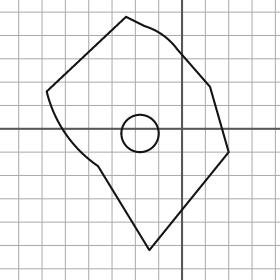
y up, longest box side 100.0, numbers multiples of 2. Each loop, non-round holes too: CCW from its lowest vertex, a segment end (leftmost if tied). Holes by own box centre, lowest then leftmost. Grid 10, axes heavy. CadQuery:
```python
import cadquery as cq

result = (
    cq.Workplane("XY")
    .moveTo(-14.0, -52.0)
    .lineTo(20.0, -10.0)
    .lineTo(12.0, 18.0)
    .lineTo(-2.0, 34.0)
    .threePointArc((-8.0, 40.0), (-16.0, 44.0))
    .lineTo(-24.0, 48.0)
    .lineTo(-58.0, 16.0)
    .threePointArc((-50.0, -2.0), (-36.0, -16.0))
    .close()
    .moveTo(-18.0, -2.0)
    .circle(8.0)
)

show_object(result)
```